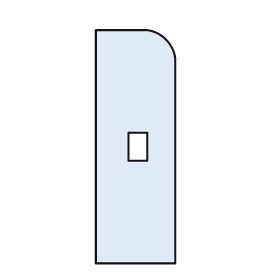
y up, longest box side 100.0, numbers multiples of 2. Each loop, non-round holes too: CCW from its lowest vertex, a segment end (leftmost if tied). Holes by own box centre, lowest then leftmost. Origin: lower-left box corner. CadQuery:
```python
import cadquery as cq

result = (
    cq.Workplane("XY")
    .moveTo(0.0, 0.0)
    .lineTo(34.0, 0.0)
    .lineTo(34.0, 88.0)
    .threePointArc((30.0, 96.0), (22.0, 100.0))
    .lineTo(0.0, 100.0)
    .close()
    .moveTo(14.0, 44.0)
    .lineTo(22.0, 44.0)
    .lineTo(22.0, 56.0)
    .lineTo(14.0, 56.0)
    .close()
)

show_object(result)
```